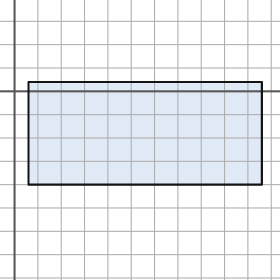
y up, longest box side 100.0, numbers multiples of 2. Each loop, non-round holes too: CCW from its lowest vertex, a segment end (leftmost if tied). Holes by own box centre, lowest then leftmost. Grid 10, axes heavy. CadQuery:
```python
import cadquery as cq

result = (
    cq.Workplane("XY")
    .moveTo(6.0, -40.0)
    .lineTo(106.0, -40.0)
    .lineTo(106.0, 4.0)
    .lineTo(6.0, 4.0)
    .close()
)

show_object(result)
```